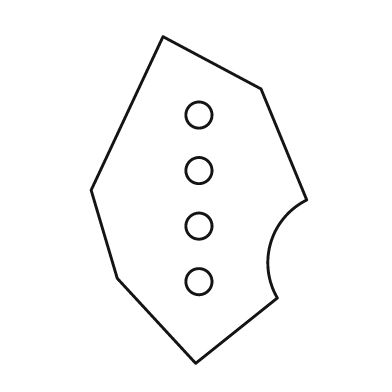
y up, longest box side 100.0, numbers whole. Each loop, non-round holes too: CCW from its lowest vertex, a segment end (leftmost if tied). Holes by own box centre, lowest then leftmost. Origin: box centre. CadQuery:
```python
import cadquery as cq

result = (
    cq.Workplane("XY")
    .moveTo(-1.0, -50.0)
    .lineTo(24.0, -30.0)
    .threePointArc((22.0, -13.0), (33.0, 0.0))
    .lineTo(19.0, 34.0)
    .lineTo(-11.0, 50.0)
    .lineTo(-33.0, 3.0)
    .lineTo(-25.0, -24.0)
    .close()
    .moveTo(0.0, -25.0)
    .circle(4.0)
    .moveTo(0.0, -8.0)
    .circle(4.0)
    .moveTo(0.0, 9.0)
    .circle(4.0)
    .moveTo(0.0, 26.0)
    .circle(4.0)
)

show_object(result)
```